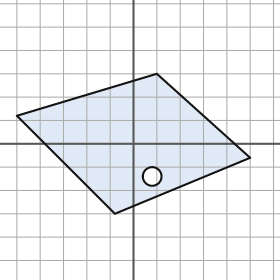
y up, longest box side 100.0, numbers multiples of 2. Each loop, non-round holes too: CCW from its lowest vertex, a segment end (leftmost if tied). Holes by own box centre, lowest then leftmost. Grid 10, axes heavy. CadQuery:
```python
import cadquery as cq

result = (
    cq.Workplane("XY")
    .moveTo(-8.0, -30.0)
    .lineTo(50.0, -6.0)
    .lineTo(10.0, 30.0)
    .lineTo(-50.0, 12.0)
    .close()
    .moveTo(8.0, -14.0)
    .circle(4.0)
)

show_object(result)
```